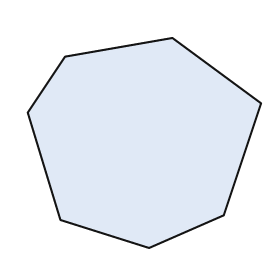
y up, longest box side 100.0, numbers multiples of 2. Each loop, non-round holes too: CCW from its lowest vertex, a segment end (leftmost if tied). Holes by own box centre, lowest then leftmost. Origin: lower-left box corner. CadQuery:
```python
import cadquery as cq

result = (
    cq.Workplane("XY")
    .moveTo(52.0, 0.0)
    .lineTo(84.0, 14.0)
    .lineTo(100.0, 62.0)
    .lineTo(62.0, 90.0)
    .lineTo(16.0, 82.0)
    .lineTo(0.0, 58.0)
    .lineTo(14.0, 12.0)
    .close()
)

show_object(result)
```